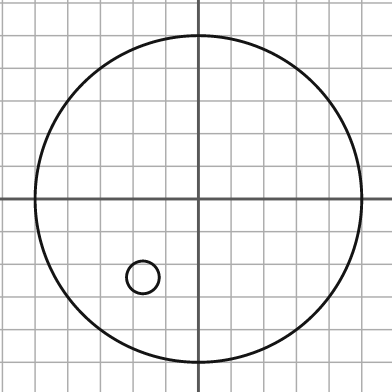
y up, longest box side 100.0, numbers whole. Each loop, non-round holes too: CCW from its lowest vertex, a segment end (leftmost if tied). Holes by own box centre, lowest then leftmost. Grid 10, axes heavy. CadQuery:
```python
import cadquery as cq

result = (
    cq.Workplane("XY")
    .moveTo(0.0, 0.0)
    .circle(50.0)
    .moveTo(-17.0, -24.0)
    .circle(5.0)
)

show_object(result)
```